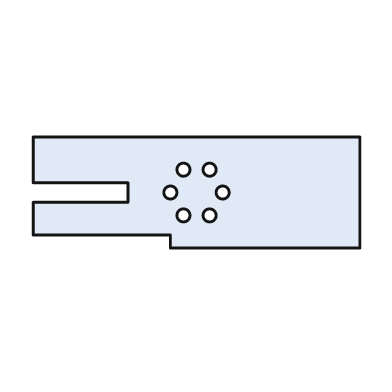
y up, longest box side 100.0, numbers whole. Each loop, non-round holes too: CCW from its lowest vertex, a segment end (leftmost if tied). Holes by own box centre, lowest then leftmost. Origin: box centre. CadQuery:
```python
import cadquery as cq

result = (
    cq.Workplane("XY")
    .moveTo(-8.0, -17.0)
    .lineTo(50.0, -17.0)
    .lineTo(50.0, 17.0)
    .lineTo(-50.0, 17.0)
    .lineTo(-50.0, 3.0)
    .lineTo(-21.0, 3.0)
    .lineTo(-21.0, -3.0)
    .lineTo(-50.0, -3.0)
    .lineTo(-50.0, -13.0)
    .lineTo(-8.0, -13.0)
    .close()
    .moveTo(-4.0, -7.0)
    .circle(2.0)
    .moveTo(4.0, -7.0)
    .circle(2.0)
    .moveTo(-8.0, 0.0)
    .circle(2.0)
    .moveTo(8.0, 0.0)
    .circle(2.0)
    .moveTo(-4.0, 7.0)
    .circle(2.0)
    .moveTo(4.0, 7.0)
    .circle(2.0)
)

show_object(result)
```